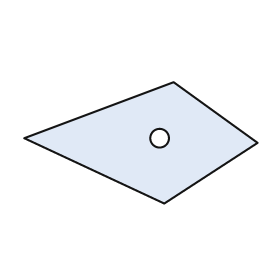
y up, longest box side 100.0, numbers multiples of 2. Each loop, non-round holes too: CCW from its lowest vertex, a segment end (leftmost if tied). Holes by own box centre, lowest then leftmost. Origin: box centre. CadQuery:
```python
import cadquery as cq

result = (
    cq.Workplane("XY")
    .moveTo(10.0, -26.0)
    .lineTo(50.0, 0.0)
    .lineTo(14.0, 26.0)
    .lineTo(-50.0, 2.0)
    .close()
    .moveTo(8.0, 2.0)
    .circle(4.0)
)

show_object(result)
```